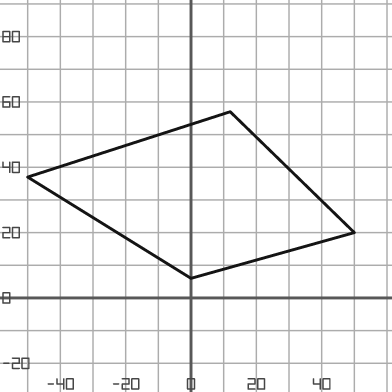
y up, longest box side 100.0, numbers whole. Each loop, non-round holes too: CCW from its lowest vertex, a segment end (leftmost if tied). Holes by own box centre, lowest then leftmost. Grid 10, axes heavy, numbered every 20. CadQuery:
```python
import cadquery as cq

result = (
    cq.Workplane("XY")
    .moveTo(0.0, 6.0)
    .lineTo(50.0, 20.0)
    .lineTo(12.0, 57.0)
    .lineTo(-50.0, 37.0)
    .close()
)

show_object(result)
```